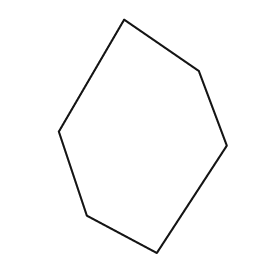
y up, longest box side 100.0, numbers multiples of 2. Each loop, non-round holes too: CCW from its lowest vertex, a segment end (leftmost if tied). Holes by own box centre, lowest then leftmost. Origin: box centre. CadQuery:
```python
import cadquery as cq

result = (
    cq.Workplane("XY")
    .moveTo(6.0, -50.0)
    .lineTo(36.0, -4.0)
    .lineTo(24.0, 28.0)
    .lineTo(-8.0, 50.0)
    .lineTo(-36.0, 2.0)
    .lineTo(-24.0, -34.0)
    .close()
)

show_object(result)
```